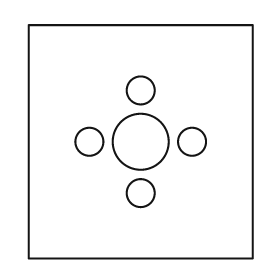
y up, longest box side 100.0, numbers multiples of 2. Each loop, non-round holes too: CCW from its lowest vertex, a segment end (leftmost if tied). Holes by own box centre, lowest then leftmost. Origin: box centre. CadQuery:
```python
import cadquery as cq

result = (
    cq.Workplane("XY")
    .moveTo(-48.0, -50.0)
    .lineTo(48.0, -50.0)
    .lineTo(48.0, 50.0)
    .lineTo(-48.0, 50.0)
    .close()
    .moveTo(0.0, -22.0)
    .circle(6.0)
    .moveTo(-22.0, 0.0)
    .circle(6.0)
    .moveTo(0.0, 0.0)
    .circle(12.0)
    .moveTo(22.0, 0.0)
    .circle(6.0)
    .moveTo(0.0, 22.0)
    .circle(6.0)
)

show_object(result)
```